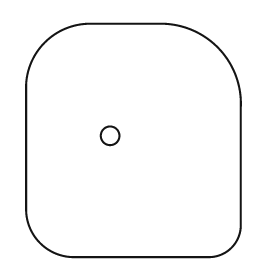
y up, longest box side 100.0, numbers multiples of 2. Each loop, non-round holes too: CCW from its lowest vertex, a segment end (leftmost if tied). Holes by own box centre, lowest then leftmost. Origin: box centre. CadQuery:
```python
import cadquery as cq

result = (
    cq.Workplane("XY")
    .moveTo(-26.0, -50.0)
    .lineTo(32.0, -50.0)
    .threePointArc((42.0, -46.0), (46.0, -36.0))
    .lineTo(46.0, 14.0)
    .threePointArc((36.0, 40.0), (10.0, 50.0))
    .lineTo(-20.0, 50.0)
    .threePointArc((-38.0, 42.0), (-46.0, 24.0))
    .lineTo(-46.0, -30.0)
    .threePointArc((-40.0, -44.0), (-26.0, -50.0))
    .close()
    .moveTo(-10.0, 2.0)
    .circle(4.0)
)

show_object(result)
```